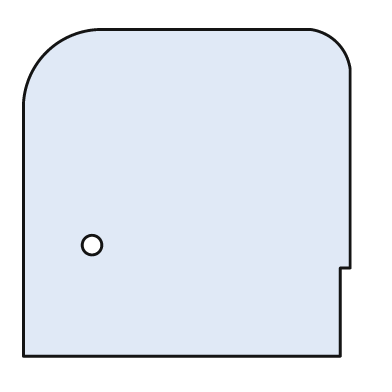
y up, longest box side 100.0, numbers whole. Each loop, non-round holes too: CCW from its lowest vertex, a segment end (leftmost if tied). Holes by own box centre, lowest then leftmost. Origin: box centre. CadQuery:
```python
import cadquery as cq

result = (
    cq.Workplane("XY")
    .moveTo(-50.0, -50.0)
    .lineTo(47.0, -50.0)
    .lineTo(47.0, -23.0)
    .lineTo(50.0, -23.0)
    .lineTo(50.0, 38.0)
    .threePointArc((46.0, 46.0), (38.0, 50.0))
    .lineTo(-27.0, 50.0)
    .threePointArc((-43.0, 43.0), (-50.0, 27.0))
    .close()
    .moveTo(-29.0, -16.0)
    .circle(3.0)
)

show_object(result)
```